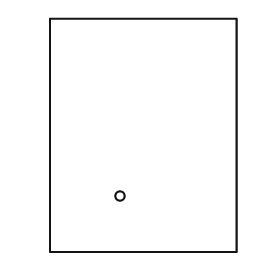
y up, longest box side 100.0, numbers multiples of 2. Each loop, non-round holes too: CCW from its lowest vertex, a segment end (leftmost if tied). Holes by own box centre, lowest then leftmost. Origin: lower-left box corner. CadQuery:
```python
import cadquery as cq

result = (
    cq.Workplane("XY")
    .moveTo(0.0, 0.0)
    .lineTo(80.0, 0.0)
    .lineTo(80.0, 100.0)
    .lineTo(0.0, 100.0)
    .close()
    .moveTo(30.0, 24.0)
    .circle(2.0)
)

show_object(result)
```